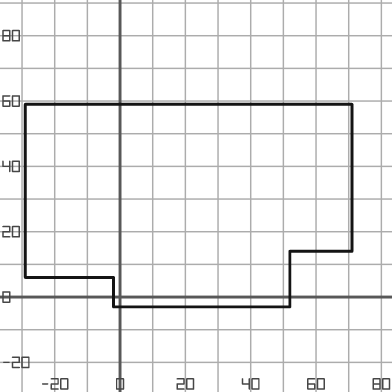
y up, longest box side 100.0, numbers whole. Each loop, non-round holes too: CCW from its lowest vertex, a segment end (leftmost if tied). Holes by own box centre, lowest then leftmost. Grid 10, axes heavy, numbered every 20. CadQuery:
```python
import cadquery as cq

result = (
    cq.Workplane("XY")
    .moveTo(-2.0, -3.0)
    .lineTo(52.0, -3.0)
    .lineTo(52.0, 14.0)
    .lineTo(71.0, 14.0)
    .lineTo(71.0, 59.0)
    .lineTo(-29.0, 59.0)
    .lineTo(-29.0, 6.0)
    .lineTo(-2.0, 6.0)
    .close()
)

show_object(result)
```